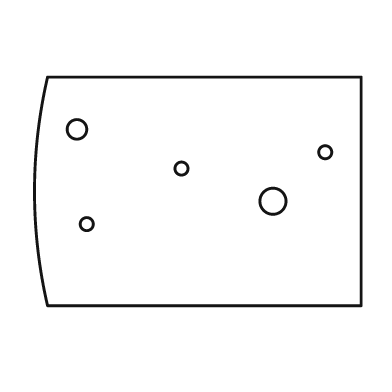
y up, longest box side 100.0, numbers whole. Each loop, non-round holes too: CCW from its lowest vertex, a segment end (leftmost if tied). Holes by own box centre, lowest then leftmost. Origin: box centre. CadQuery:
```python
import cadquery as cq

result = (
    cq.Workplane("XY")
    .moveTo(-46.0, -35.0)
    .lineTo(50.0, -35.0)
    .lineTo(50.0, 35.0)
    .lineTo(-46.0, 35.0)
    .threePointArc((-50.0, 0.0), (-46.0, -35.0))
    .close()
    .moveTo(-34.0, -10.0)
    .circle(2.0)
    .moveTo(23.0, -3.0)
    .circle(4.0)
    .moveTo(-5.0, 7.0)
    .circle(2.0)
    .moveTo(39.0, 12.0)
    .circle(2.0)
    .moveTo(-37.0, 19.0)
    .circle(3.0)
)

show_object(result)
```